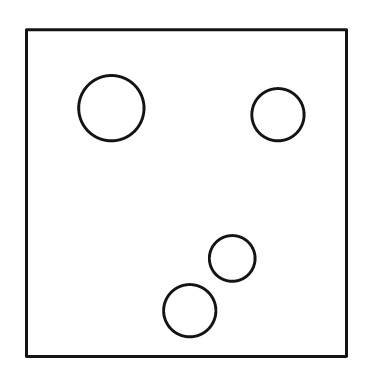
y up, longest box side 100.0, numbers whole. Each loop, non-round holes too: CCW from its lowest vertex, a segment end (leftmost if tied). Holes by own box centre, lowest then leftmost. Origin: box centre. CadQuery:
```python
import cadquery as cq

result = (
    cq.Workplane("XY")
    .moveTo(-49.0, -50.0)
    .lineTo(49.0, -50.0)
    .lineTo(49.0, 50.0)
    .lineTo(-49.0, 50.0)
    .close()
    .moveTo(1.0, -36.0)
    .circle(8.0)
    .moveTo(14.0, -20.0)
    .circle(7.0)
    .moveTo(28.0, 24.0)
    .circle(8.0)
    .moveTo(-23.0, 26.0)
    .circle(10.0)
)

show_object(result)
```